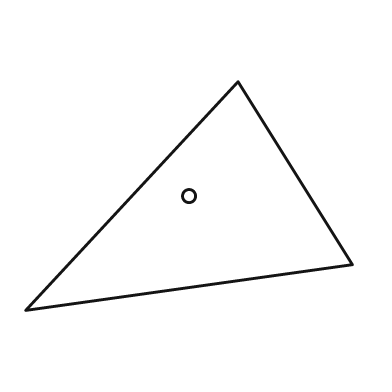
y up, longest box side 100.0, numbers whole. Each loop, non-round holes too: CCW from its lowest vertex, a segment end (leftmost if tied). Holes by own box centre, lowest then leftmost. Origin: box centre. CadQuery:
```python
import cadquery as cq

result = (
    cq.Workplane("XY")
    .moveTo(-50.0, -35.0)
    .lineTo(50.0, -21.0)
    .lineTo(15.0, 35.0)
    .close()
    .moveTo(0.0, 0.0)
    .circle(2.0)
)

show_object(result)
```